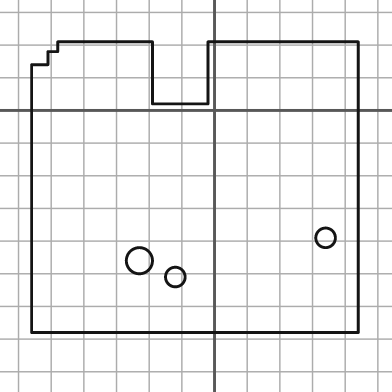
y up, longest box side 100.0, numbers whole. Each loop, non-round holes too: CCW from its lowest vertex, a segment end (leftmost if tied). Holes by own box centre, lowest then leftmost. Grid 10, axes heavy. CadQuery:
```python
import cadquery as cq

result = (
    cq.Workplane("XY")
    .moveTo(-56.0, -68.0)
    .lineTo(44.0, -68.0)
    .lineTo(44.0, 21.0)
    .lineTo(-2.0, 21.0)
    .lineTo(-2.0, 2.0)
    .lineTo(-19.0, 2.0)
    .lineTo(-19.0, 21.0)
    .lineTo(-48.0, 21.0)
    .lineTo(-48.0, 18.0)
    .lineTo(-51.0, 18.0)
    .lineTo(-51.0, 14.0)
    .lineTo(-56.0, 14.0)
    .close()
    .moveTo(-12.0, -51.0)
    .circle(3.0)
    .moveTo(-23.0, -46.0)
    .circle(4.0)
    .moveTo(34.0, -39.0)
    .circle(3.0)
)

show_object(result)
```